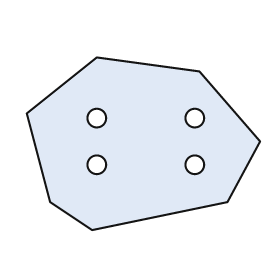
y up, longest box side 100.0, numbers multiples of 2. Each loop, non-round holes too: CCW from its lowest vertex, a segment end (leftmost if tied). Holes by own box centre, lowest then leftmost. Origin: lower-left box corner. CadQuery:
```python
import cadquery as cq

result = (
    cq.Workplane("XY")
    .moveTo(28.0, 0.0)
    .lineTo(86.0, 12.0)
    .lineTo(100.0, 38.0)
    .lineTo(74.0, 68.0)
    .lineTo(30.0, 74.0)
    .lineTo(0.0, 50.0)
    .lineTo(10.0, 12.0)
    .close()
    .moveTo(30.0, 28.0)
    .circle(4.0)
    .moveTo(72.0, 28.0)
    .circle(4.0)
    .moveTo(30.0, 48.0)
    .circle(4.0)
    .moveTo(72.0, 48.0)
    .circle(4.0)
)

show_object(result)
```